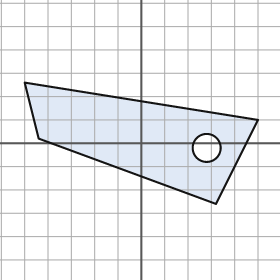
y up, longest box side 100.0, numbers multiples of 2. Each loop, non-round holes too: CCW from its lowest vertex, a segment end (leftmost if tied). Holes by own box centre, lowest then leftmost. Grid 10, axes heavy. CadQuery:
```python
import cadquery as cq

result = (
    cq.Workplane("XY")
    .moveTo(32.0, -26.0)
    .lineTo(50.0, 10.0)
    .lineTo(-50.0, 26.0)
    .lineTo(-44.0, 2.0)
    .close()
    .moveTo(28.0, -2.0)
    .circle(6.0)
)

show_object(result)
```